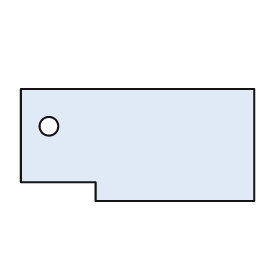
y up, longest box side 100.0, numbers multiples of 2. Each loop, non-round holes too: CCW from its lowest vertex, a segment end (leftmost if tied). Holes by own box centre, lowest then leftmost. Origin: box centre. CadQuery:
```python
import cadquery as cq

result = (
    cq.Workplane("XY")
    .moveTo(-18.0, -24.0)
    .lineTo(50.0, -24.0)
    .lineTo(50.0, 24.0)
    .lineTo(-50.0, 24.0)
    .lineTo(-50.0, -16.0)
    .lineTo(-18.0, -16.0)
    .close()
    .moveTo(-38.0, 8.0)
    .circle(4.0)
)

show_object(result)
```